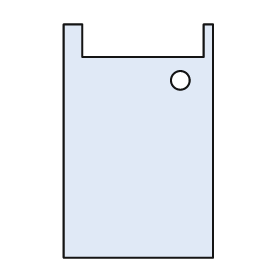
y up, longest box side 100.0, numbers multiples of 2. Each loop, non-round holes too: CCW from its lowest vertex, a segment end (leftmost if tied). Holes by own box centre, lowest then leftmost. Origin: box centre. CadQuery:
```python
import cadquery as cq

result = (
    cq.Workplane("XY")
    .moveTo(-32.0, -50.0)
    .lineTo(32.0, -50.0)
    .lineTo(32.0, 50.0)
    .lineTo(28.0, 50.0)
    .lineTo(28.0, 36.0)
    .lineTo(-24.0, 36.0)
    .lineTo(-24.0, 50.0)
    .lineTo(-32.0, 50.0)
    .close()
    .moveTo(18.0, 26.0)
    .circle(4.0)
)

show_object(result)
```